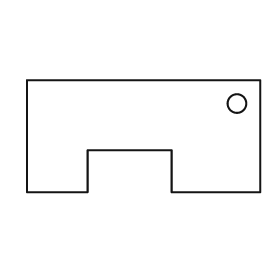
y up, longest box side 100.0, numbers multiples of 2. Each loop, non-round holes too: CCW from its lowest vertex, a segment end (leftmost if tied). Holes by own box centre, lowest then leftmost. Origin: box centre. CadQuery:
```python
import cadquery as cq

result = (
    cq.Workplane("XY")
    .moveTo(-50.0, -24.0)
    .lineTo(-24.0, -24.0)
    .lineTo(-24.0, -6.0)
    .lineTo(12.0, -6.0)
    .lineTo(12.0, -24.0)
    .lineTo(50.0, -24.0)
    .lineTo(50.0, 24.0)
    .lineTo(-50.0, 24.0)
    .close()
    .moveTo(40.0, 14.0)
    .circle(4.0)
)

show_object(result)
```